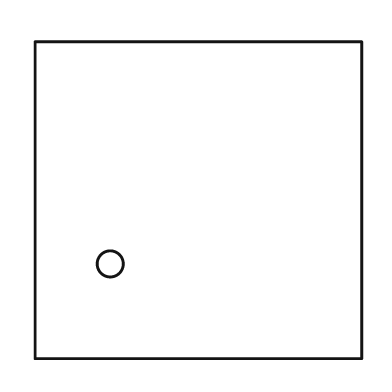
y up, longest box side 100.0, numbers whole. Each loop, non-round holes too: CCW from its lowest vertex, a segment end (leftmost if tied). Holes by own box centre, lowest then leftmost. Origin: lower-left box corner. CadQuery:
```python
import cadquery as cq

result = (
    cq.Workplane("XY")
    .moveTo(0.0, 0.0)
    .lineTo(100.0, 0.0)
    .lineTo(100.0, 97.0)
    .lineTo(0.0, 97.0)
    .close()
    .moveTo(23.0, 29.0)
    .circle(4.0)
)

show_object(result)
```